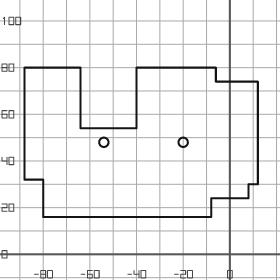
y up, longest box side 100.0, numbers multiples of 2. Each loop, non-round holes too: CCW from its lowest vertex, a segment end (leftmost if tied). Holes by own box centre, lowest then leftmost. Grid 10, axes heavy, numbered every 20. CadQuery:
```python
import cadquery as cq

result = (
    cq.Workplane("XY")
    .moveTo(-80.0, 16.0)
    .lineTo(-8.0, 16.0)
    .lineTo(-8.0, 24.0)
    .lineTo(8.0, 24.0)
    .lineTo(8.0, 30.0)
    .lineTo(12.0, 30.0)
    .lineTo(12.0, 74.0)
    .lineTo(-6.0, 74.0)
    .lineTo(-6.0, 80.0)
    .lineTo(-40.0, 80.0)
    .lineTo(-40.0, 54.0)
    .lineTo(-64.0, 54.0)
    .lineTo(-64.0, 80.0)
    .lineTo(-88.0, 80.0)
    .lineTo(-88.0, 32.0)
    .lineTo(-80.0, 32.0)
    .close()
    .moveTo(-54.0, 48.0)
    .circle(2.0)
    .moveTo(-20.0, 48.0)
    .circle(2.0)
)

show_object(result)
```